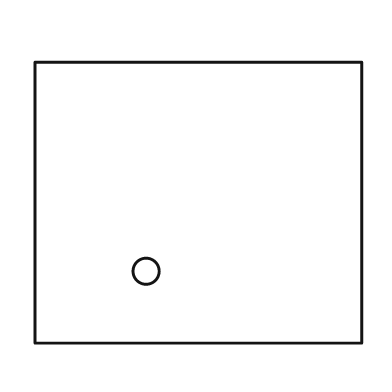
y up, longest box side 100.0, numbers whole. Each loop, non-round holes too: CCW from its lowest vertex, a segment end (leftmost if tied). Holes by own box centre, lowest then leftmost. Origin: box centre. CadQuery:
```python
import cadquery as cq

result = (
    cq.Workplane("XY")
    .moveTo(-50.0, -43.0)
    .lineTo(50.0, -43.0)
    .lineTo(50.0, 43.0)
    .lineTo(-50.0, 43.0)
    .close()
    .moveTo(-16.0, -21.0)
    .circle(4.0)
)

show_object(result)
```